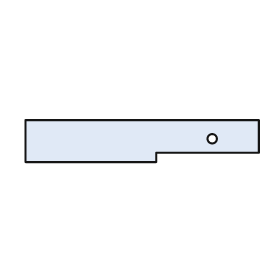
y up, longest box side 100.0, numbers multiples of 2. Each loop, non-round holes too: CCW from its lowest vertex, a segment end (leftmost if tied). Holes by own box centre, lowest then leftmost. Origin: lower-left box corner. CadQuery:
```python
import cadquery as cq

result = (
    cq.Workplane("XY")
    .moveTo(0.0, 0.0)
    .lineTo(56.0, 0.0)
    .lineTo(56.0, 4.0)
    .lineTo(100.0, 4.0)
    .lineTo(100.0, 18.0)
    .lineTo(0.0, 18.0)
    .close()
    .moveTo(80.0, 10.0)
    .circle(2.0)
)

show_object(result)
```